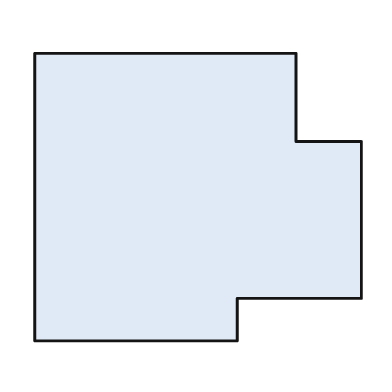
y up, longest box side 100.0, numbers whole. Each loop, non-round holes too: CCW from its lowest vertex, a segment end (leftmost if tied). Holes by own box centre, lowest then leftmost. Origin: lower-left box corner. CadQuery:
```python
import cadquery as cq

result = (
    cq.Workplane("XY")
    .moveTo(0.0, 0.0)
    .lineTo(62.0, 0.0)
    .lineTo(62.0, 13.0)
    .lineTo(100.0, 13.0)
    .lineTo(100.0, 61.0)
    .lineTo(80.0, 61.0)
    .lineTo(80.0, 88.0)
    .lineTo(0.0, 88.0)
    .close()
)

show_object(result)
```